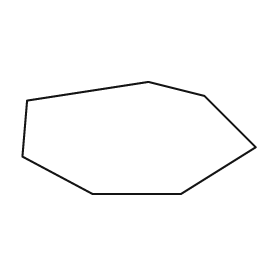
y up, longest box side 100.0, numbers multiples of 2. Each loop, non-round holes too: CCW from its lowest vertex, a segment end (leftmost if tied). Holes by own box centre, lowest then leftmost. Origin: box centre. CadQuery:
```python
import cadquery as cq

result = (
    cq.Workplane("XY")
    .moveTo(-20.0, -24.0)
    .lineTo(18.0, -24.0)
    .lineTo(50.0, -4.0)
    .lineTo(28.0, 18.0)
    .lineTo(4.0, 24.0)
    .lineTo(-48.0, 16.0)
    .lineTo(-50.0, -8.0)
    .close()
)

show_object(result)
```